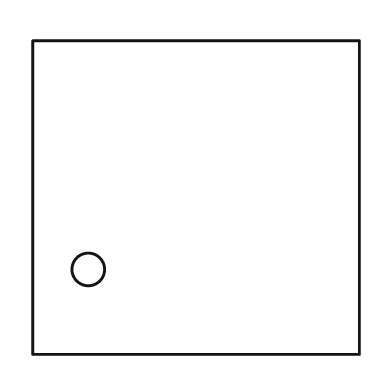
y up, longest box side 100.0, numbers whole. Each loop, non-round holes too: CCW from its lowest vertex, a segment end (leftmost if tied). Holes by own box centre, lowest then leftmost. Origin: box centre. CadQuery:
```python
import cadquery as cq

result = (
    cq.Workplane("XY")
    .moveTo(-50.0, -48.0)
    .lineTo(50.0, -48.0)
    .lineTo(50.0, 48.0)
    .lineTo(-50.0, 48.0)
    .close()
    .moveTo(-33.0, -22.0)
    .circle(5.0)
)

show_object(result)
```